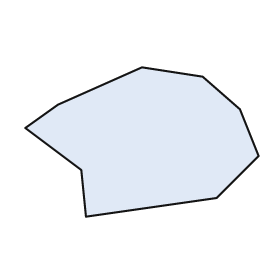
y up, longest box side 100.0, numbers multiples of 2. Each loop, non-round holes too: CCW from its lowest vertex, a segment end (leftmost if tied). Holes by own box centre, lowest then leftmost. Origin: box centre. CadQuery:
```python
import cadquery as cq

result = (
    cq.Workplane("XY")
    .moveTo(-24.0, -32.0)
    .lineTo(32.0, -24.0)
    .lineTo(50.0, -6.0)
    .lineTo(42.0, 14.0)
    .lineTo(26.0, 28.0)
    .lineTo(0.0, 32.0)
    .lineTo(-36.0, 16.0)
    .lineTo(-50.0, 6.0)
    .lineTo(-26.0, -12.0)
    .close()
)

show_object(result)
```